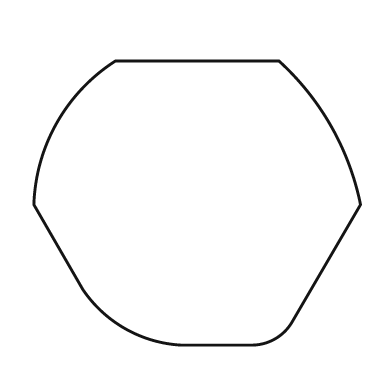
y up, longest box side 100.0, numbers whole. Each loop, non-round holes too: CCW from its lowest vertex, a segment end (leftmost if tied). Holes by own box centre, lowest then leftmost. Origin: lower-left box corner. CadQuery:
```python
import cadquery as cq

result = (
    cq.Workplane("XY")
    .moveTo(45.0, 0.0)
    .lineTo(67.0, 0.0)
    .threePointArc((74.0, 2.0), (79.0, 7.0))
    .lineTo(100.0, 43.0)
    .threePointArc((91.0, 67.0), (75.0, 87.0))
    .lineTo(25.0, 87.0)
    .threePointArc((7.0, 68.0), (0.0, 43.0))
    .lineTo(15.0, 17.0)
    .threePointArc((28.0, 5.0), (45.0, 0.0))
    .close()
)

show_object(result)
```